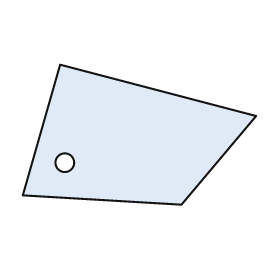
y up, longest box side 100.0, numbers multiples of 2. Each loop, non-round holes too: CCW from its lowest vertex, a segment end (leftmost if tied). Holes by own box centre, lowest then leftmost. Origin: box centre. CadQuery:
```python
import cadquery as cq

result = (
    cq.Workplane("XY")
    .moveTo(18.0, -30.0)
    .lineTo(50.0, 8.0)
    .lineTo(-34.0, 30.0)
    .lineTo(-50.0, -26.0)
    .close()
    .moveTo(-32.0, -12.0)
    .circle(4.0)
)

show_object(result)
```